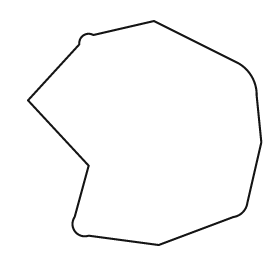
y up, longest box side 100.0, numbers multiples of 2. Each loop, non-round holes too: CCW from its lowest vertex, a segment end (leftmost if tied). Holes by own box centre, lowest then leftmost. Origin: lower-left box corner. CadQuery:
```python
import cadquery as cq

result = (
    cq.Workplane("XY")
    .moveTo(56.0, 0.0)
    .lineTo(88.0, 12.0)
    .threePointArc((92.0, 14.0), (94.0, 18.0))
    .lineTo(100.0, 44.0)
    .lineTo(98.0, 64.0)
    .threePointArc((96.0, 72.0), (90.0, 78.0))
    .lineTo(54.0, 96.0)
    .lineTo(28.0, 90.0)
    .threePointArc((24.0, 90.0), (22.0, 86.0))
    .lineTo(0.0, 62.0)
    .lineTo(26.0, 34.0)
    .lineTo(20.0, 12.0)
    .threePointArc((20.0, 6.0), (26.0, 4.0))
    .close()
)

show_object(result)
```